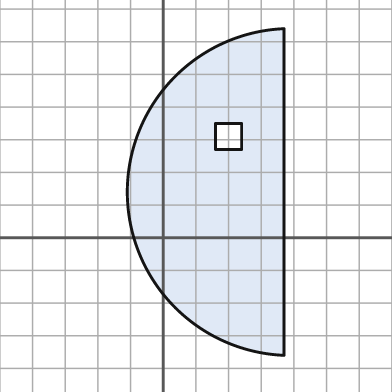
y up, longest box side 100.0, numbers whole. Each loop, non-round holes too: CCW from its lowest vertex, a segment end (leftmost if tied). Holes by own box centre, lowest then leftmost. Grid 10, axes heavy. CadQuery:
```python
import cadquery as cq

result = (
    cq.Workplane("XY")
    .moveTo(37.0, -36.0)
    .lineTo(37.0, 64.0)
    .threePointArc((-11.0, 14.0), (37.0, -36.0))
    .close()
    .moveTo(16.0, 27.0)
    .lineTo(24.0, 27.0)
    .lineTo(24.0, 35.0)
    .lineTo(16.0, 35.0)
    .close()
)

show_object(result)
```